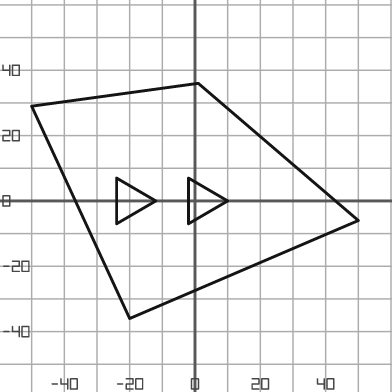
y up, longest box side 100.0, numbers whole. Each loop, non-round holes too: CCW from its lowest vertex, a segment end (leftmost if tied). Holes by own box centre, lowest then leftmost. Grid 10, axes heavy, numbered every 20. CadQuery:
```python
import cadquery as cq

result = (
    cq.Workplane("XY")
    .moveTo(-20.0, -36.0)
    .lineTo(50.0, -6.0)
    .lineTo(1.0, 36.0)
    .lineTo(-50.0, 29.0)
    .close()
    .moveTo(-24.0, -7.0)
    .lineTo(-12.0, 0.0)
    .lineTo(-24.0, 7.0)
    .close()
    .moveTo(-2.0, -7.0)
    .lineTo(10.0, 0.0)
    .lineTo(-2.0, 7.0)
    .close()
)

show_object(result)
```